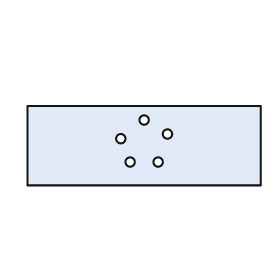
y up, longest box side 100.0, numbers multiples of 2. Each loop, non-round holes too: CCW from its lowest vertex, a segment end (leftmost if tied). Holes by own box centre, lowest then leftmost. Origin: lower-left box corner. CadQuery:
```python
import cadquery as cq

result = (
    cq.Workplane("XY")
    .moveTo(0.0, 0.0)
    .lineTo(100.0, 0.0)
    .lineTo(100.0, 34.0)
    .lineTo(0.0, 34.0)
    .close()
    .moveTo(44.0, 10.0)
    .circle(2.0)
    .moveTo(56.0, 10.0)
    .circle(2.0)
    .moveTo(40.0, 20.0)
    .circle(2.0)
    .moveTo(60.0, 22.0)
    .circle(2.0)
    .moveTo(50.0, 28.0)
    .circle(2.0)
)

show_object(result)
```